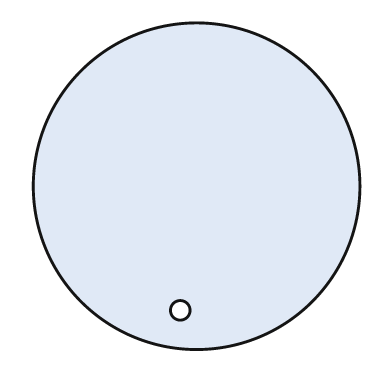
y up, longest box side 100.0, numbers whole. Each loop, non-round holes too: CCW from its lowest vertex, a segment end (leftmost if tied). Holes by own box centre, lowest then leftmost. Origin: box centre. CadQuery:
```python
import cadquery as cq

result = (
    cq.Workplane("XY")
    .moveTo(0.0, 0.0)
    .circle(50.0)
    .moveTo(-5.0, -38.0)
    .circle(3.0)
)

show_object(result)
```